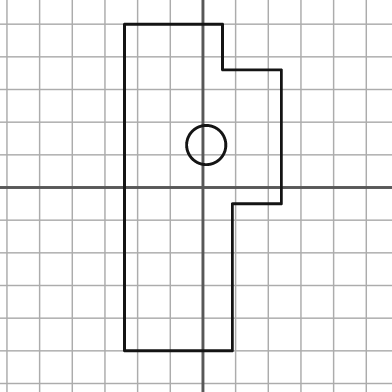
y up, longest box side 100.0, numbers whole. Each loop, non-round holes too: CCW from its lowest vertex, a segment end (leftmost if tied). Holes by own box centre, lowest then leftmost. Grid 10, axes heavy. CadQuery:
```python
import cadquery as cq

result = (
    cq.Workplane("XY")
    .moveTo(-24.0, -50.0)
    .lineTo(9.0, -50.0)
    .lineTo(9.0, -5.0)
    .lineTo(24.0, -5.0)
    .lineTo(24.0, 36.0)
    .lineTo(6.0, 36.0)
    .lineTo(6.0, 50.0)
    .lineTo(-24.0, 50.0)
    .close()
    .moveTo(1.0, 13.0)
    .circle(6.0)
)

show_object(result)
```